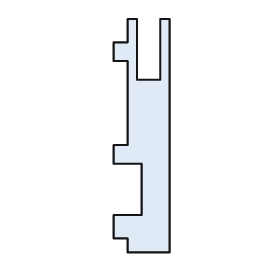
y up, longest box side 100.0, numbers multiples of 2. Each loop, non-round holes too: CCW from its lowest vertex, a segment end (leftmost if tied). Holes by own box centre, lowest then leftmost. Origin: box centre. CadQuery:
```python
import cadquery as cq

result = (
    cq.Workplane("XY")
    .moveTo(-6.0, -50.0)
    .lineTo(12.0, -50.0)
    .lineTo(12.0, 50.0)
    .lineTo(8.0, 50.0)
    .lineTo(8.0, 24.0)
    .lineTo(-2.0, 24.0)
    .lineTo(-2.0, 50.0)
    .lineTo(-6.0, 50.0)
    .lineTo(-6.0, 40.0)
    .lineTo(-12.0, 40.0)
    .lineTo(-12.0, 32.0)
    .lineTo(-6.0, 32.0)
    .lineTo(-6.0, -4.0)
    .lineTo(-12.0, -4.0)
    .lineTo(-12.0, -12.0)
    .lineTo(0.0, -12.0)
    .lineTo(0.0, -34.0)
    .lineTo(-12.0, -34.0)
    .lineTo(-12.0, -44.0)
    .lineTo(-6.0, -44.0)
    .close()
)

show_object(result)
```